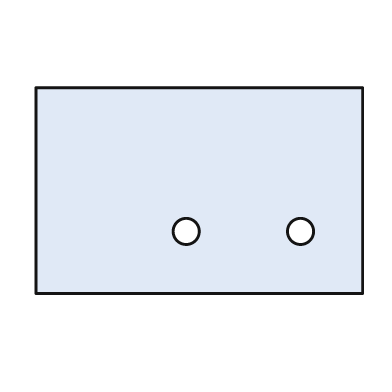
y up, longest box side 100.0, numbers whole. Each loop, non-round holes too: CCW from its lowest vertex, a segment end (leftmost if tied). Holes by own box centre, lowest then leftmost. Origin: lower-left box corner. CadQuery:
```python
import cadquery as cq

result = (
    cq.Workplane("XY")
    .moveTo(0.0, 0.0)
    .lineTo(100.0, 0.0)
    .lineTo(100.0, 63.0)
    .lineTo(0.0, 63.0)
    .close()
    .moveTo(46.0, 19.0)
    .circle(4.0)
    .moveTo(81.0, 19.0)
    .circle(4.0)
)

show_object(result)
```